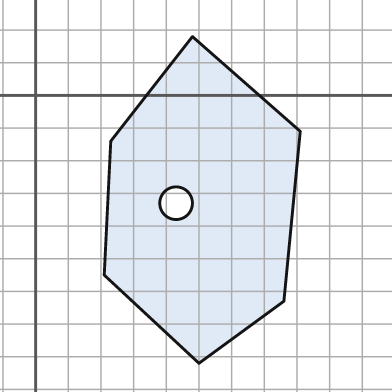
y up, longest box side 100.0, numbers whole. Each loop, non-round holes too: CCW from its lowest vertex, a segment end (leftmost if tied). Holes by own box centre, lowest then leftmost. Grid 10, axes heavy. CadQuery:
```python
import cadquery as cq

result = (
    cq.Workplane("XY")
    .moveTo(50.0, -82.0)
    .lineTo(76.0, -63.0)
    .lineTo(81.0, -11.0)
    .lineTo(48.0, 18.0)
    .lineTo(23.0, -14.0)
    .lineTo(21.0, -55.0)
    .close()
    .moveTo(43.0, -33.0)
    .circle(5.0)
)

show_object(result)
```